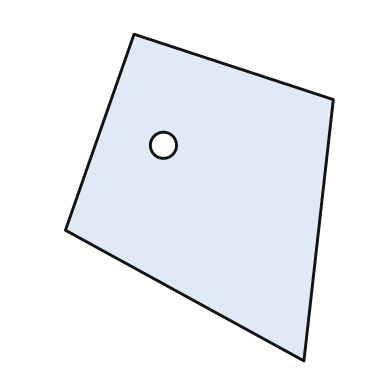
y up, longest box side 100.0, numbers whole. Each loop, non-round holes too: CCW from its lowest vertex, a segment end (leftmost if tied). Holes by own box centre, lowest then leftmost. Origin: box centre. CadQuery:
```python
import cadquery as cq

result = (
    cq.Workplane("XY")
    .moveTo(32.0, -50.0)
    .lineTo(41.0, 30.0)
    .lineTo(-20.0, 50.0)
    .lineTo(-41.0, -10.0)
    .close()
    .moveTo(-11.0, 16.0)
    .circle(4.0)
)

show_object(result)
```